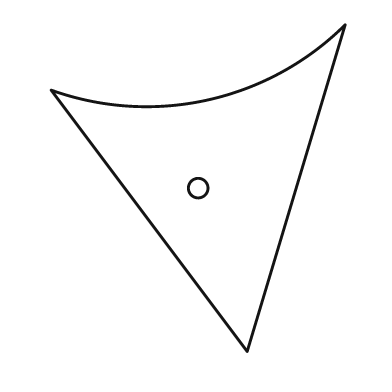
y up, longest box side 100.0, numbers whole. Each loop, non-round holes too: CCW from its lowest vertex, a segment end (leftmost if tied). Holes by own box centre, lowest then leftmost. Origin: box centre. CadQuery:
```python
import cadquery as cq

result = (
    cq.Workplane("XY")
    .moveTo(15.0, -50.0)
    .lineTo(45.0, 50.0)
    .threePointArc((3.0, 27.0), (-45.0, 30.0))
    .close()
    .moveTo(0.0, 0.0)
    .circle(3.0)
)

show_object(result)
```